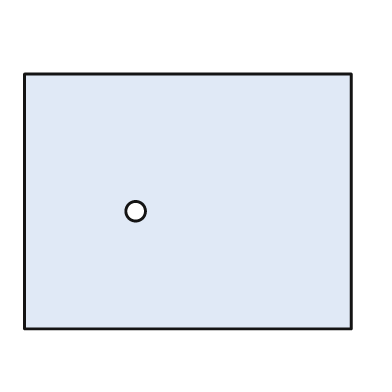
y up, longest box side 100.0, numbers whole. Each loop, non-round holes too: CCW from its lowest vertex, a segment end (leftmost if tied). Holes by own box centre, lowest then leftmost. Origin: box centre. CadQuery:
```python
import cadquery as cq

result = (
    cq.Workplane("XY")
    .moveTo(-50.0, -39.0)
    .lineTo(50.0, -39.0)
    .lineTo(50.0, 39.0)
    .lineTo(-50.0, 39.0)
    .close()
    .moveTo(-16.0, -3.0)
    .circle(3.0)
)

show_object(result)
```